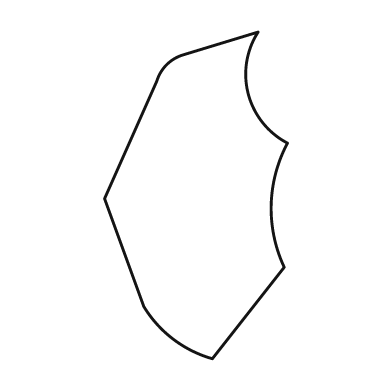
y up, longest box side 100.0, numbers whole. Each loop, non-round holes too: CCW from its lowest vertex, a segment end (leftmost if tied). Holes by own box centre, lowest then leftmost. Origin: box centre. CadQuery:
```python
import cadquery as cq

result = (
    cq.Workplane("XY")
    .moveTo(5.0, -50.0)
    .lineTo(27.0, -22.0)
    .threePointArc((23.0, -3.0), (28.0, 16.0))
    .threePointArc((16.0, 31.0), (19.0, 50.0))
    .lineTo(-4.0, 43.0)
    .threePointArc((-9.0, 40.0), (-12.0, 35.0))
    .lineTo(-28.0, -1.0)
    .lineTo(-16.0, -34.0)
    .threePointArc((-7.0, -44.0), (5.0, -50.0))
    .close()
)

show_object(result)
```